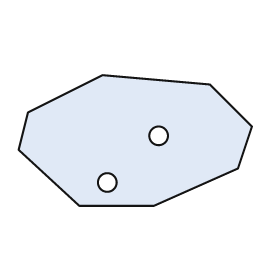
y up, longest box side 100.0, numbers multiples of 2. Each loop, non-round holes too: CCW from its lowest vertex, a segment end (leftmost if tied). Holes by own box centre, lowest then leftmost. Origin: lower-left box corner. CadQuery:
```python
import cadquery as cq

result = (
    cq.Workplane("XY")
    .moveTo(26.0, 0.0)
    .lineTo(58.0, 0.0)
    .lineTo(94.0, 16.0)
    .lineTo(100.0, 34.0)
    .lineTo(82.0, 52.0)
    .lineTo(36.0, 56.0)
    .lineTo(4.0, 40.0)
    .lineTo(0.0, 24.0)
    .close()
    .moveTo(38.0, 10.0)
    .circle(4.0)
    .moveTo(60.0, 30.0)
    .circle(4.0)
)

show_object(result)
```